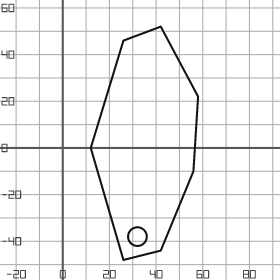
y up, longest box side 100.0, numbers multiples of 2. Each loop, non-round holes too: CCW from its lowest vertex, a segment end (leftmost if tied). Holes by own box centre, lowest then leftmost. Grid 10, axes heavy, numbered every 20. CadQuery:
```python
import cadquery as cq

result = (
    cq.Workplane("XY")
    .moveTo(26.0, -48.0)
    .lineTo(42.0, -44.0)
    .lineTo(56.0, -10.0)
    .lineTo(58.0, 22.0)
    .lineTo(42.0, 52.0)
    .lineTo(26.0, 46.0)
    .lineTo(12.0, 0.0)
    .close()
    .moveTo(32.0, -38.0)
    .circle(4.0)
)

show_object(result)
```